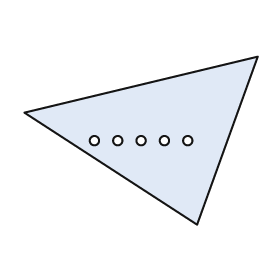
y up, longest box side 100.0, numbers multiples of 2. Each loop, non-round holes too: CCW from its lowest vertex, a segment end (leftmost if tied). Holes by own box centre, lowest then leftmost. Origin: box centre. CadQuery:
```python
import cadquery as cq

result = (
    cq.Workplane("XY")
    .moveTo(24.0, -36.0)
    .lineTo(50.0, 36.0)
    .lineTo(-50.0, 12.0)
    .close()
    .moveTo(-20.0, 0.0)
    .circle(2.0)
    .moveTo(-10.0, 0.0)
    .circle(2.0)
    .moveTo(0.0, 0.0)
    .circle(2.0)
    .moveTo(10.0, 0.0)
    .circle(2.0)
    .moveTo(20.0, 0.0)
    .circle(2.0)
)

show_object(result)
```